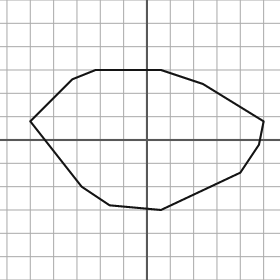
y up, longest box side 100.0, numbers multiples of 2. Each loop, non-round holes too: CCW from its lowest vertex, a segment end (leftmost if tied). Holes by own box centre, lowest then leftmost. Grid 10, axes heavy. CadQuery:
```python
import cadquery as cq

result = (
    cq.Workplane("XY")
    .moveTo(6.0, -30.0)
    .lineTo(40.0, -14.0)
    .lineTo(48.0, -2.0)
    .lineTo(50.0, 8.0)
    .lineTo(24.0, 24.0)
    .lineTo(6.0, 30.0)
    .lineTo(-22.0, 30.0)
    .lineTo(-32.0, 26.0)
    .lineTo(-50.0, 8.0)
    .lineTo(-28.0, -20.0)
    .lineTo(-16.0, -28.0)
    .close()
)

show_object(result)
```